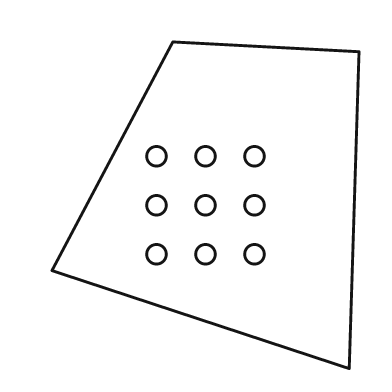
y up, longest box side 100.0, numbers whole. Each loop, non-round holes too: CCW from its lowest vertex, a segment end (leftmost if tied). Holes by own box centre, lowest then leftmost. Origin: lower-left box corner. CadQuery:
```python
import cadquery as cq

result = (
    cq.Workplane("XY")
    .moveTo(91.0, 0.0)
    .lineTo(94.0, 97.0)
    .lineTo(37.0, 100.0)
    .lineTo(0.0, 30.0)
    .close()
    .moveTo(32.0, 35.0)
    .circle(3.0)
    .moveTo(47.0, 35.0)
    .circle(3.0)
    .moveTo(62.0, 35.0)
    .circle(3.0)
    .moveTo(32.0, 50.0)
    .circle(3.0)
    .moveTo(47.0, 50.0)
    .circle(3.0)
    .moveTo(62.0, 50.0)
    .circle(3.0)
    .moveTo(32.0, 65.0)
    .circle(3.0)
    .moveTo(47.0, 65.0)
    .circle(3.0)
    .moveTo(62.0, 65.0)
    .circle(3.0)
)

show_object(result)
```